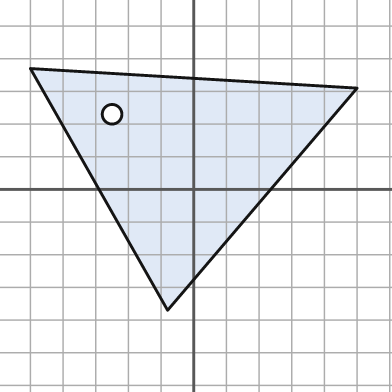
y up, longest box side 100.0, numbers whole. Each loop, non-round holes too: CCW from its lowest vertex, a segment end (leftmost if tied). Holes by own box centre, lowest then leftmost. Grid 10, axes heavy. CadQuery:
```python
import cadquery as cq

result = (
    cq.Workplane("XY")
    .moveTo(-8.0, -37.0)
    .lineTo(50.0, 31.0)
    .lineTo(-50.0, 37.0)
    .close()
    .moveTo(-25.0, 23.0)
    .circle(3.0)
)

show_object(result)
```